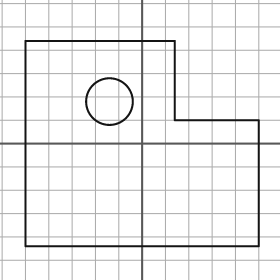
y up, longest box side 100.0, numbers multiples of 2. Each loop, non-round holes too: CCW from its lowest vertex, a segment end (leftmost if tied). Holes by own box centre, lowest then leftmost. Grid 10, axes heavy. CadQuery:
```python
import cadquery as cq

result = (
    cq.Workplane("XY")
    .moveTo(-50.0, -44.0)
    .lineTo(50.0, -44.0)
    .lineTo(50.0, 10.0)
    .lineTo(14.0, 10.0)
    .lineTo(14.0, 44.0)
    .lineTo(-50.0, 44.0)
    .close()
    .moveTo(-14.0, 18.0)
    .circle(10.0)
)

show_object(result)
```